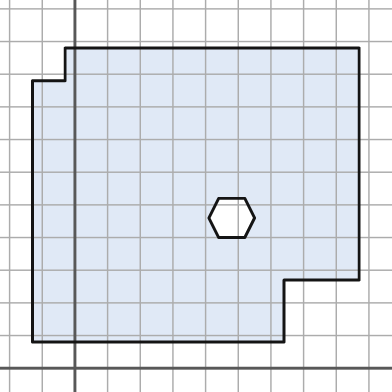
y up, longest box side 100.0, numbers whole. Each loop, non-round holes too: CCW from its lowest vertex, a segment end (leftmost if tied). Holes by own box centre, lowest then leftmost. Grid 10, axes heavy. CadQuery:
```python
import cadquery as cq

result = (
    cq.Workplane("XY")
    .moveTo(-13.0, 8.0)
    .lineTo(64.0, 8.0)
    .lineTo(64.0, 27.0)
    .lineTo(87.0, 27.0)
    .lineTo(87.0, 98.0)
    .lineTo(-3.0, 98.0)
    .lineTo(-3.0, 88.0)
    .lineTo(-13.0, 88.0)
    .close()
    .moveTo(44.0, 40.0)
    .lineTo(52.0, 40.0)
    .lineTo(55.0, 46.0)
    .lineTo(52.0, 52.0)
    .lineTo(44.0, 52.0)
    .lineTo(41.0, 46.0)
    .close()
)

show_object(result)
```